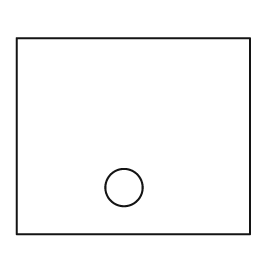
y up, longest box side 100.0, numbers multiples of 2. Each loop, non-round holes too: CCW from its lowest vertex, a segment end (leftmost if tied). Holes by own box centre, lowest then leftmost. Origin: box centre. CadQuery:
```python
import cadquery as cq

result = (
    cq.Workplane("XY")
    .moveTo(-50.0, -42.0)
    .lineTo(50.0, -42.0)
    .lineTo(50.0, 42.0)
    .lineTo(-50.0, 42.0)
    .close()
    .moveTo(-4.0, -22.0)
    .circle(8.0)
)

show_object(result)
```